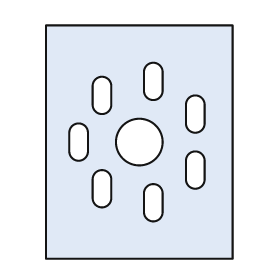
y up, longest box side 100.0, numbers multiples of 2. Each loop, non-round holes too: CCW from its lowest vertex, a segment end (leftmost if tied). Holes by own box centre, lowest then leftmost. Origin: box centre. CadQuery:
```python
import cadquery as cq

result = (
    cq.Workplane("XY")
    .moveTo(-40.0, -50.0)
    .lineTo(40.0, -50.0)
    .lineTo(40.0, 50.0)
    .lineTo(-40.0, 50.0)
    .close()
    .moveTo(2.0, -30.0)
    .threePointArc((6.0, -34.0), (10.0, -30.0))
    .lineTo(10.0, -22.0)
    .threePointArc((6.0, -18.0), (2.0, -22.0))
    .close()
    .moveTo(-20.0, -24.0)
    .threePointArc((-16.0, -28.0), (-12.0, -24.0))
    .lineTo(-12.0, -16.0)
    .threePointArc((-16.0, -12.0), (-20.0, -16.0))
    .close()
    .moveTo(20.0, -16.0)
    .threePointArc((24.0, -20.0), (28.0, -16.0))
    .lineTo(28.0, -8.0)
    .threePointArc((24.0, -4.0), (20.0, -8.0))
    .close()
    .moveTo(-30.0, -4.0)
    .threePointArc((-26.0, -8.0), (-22.0, -4.0))
    .lineTo(-22.0, 4.0)
    .threePointArc((-26.0, 8.0), (-30.0, 4.0))
    .close()
    .moveTo(0.0, 0.0)
    .circle(10.0)
    .moveTo(20.0, 8.0)
    .threePointArc((24.0, 4.0), (28.0, 8.0))
    .lineTo(28.0, 16.0)
    .threePointArc((24.0, 20.0), (20.0, 16.0))
    .close()
    .moveTo(-20.0, 16.0)
    .threePointArc((-16.0, 12.0), (-12.0, 16.0))
    .lineTo(-12.0, 24.0)
    .threePointArc((-16.0, 28.0), (-20.0, 24.0))
    .close()
    .moveTo(2.0, 22.0)
    .threePointArc((6.0, 18.0), (10.0, 22.0))
    .lineTo(10.0, 30.0)
    .threePointArc((6.0, 34.0), (2.0, 30.0))
    .close()
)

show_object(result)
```